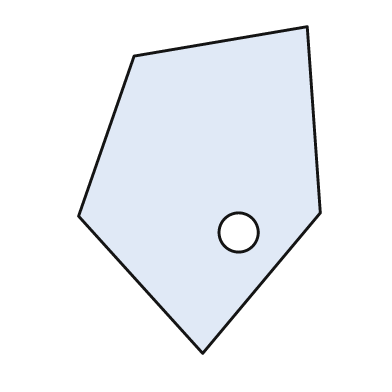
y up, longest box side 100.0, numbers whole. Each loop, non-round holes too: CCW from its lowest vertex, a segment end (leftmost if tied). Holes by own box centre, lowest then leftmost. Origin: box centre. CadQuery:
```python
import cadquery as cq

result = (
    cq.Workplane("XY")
    .moveTo(1.0, -50.0)
    .lineTo(37.0, -7.0)
    .lineTo(33.0, 50.0)
    .lineTo(-20.0, 41.0)
    .lineTo(-37.0, -8.0)
    .close()
    .moveTo(12.0, -13.0)
    .circle(6.0)
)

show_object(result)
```